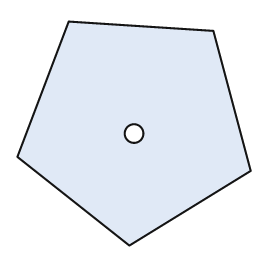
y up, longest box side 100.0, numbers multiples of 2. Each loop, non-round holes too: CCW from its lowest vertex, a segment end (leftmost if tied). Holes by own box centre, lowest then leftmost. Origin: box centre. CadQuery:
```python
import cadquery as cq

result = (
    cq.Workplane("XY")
    .moveTo(-2.0, -48.0)
    .lineTo(50.0, -16.0)
    .lineTo(34.0, 44.0)
    .lineTo(-28.0, 48.0)
    .lineTo(-50.0, -10.0)
    .close()
    .moveTo(0.0, 0.0)
    .circle(4.0)
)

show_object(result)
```